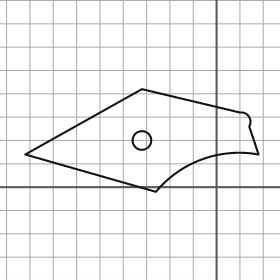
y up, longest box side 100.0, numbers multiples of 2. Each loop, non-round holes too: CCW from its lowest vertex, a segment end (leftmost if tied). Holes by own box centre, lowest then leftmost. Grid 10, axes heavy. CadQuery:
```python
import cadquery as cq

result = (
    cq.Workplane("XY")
    .moveTo(-26.0, -2.0)
    .threePointArc((-6.0, 12.0), (18.0, 14.0))
    .lineTo(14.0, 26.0)
    .threePointArc((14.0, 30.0), (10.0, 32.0))
    .lineTo(-32.0, 42.0)
    .lineTo(-82.0, 14.0)
    .close()
    .moveTo(-32.0, 20.0)
    .circle(4.0)
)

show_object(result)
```